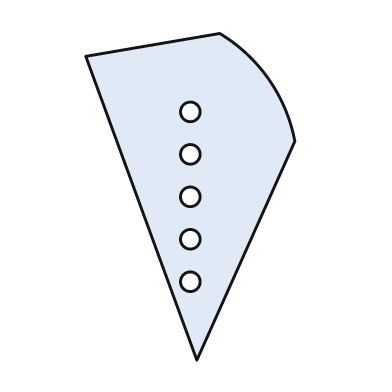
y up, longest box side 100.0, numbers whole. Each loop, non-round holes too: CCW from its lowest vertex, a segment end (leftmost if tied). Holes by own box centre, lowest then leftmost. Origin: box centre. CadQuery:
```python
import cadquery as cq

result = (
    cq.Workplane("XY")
    .moveTo(2.0, -50.0)
    .lineTo(32.0, 17.0)
    .threePointArc((24.0, 36.0), (9.0, 50.0))
    .lineTo(-32.0, 43.0)
    .close()
    .moveTo(0.0, -26.0)
    .circle(3.0)
    .moveTo(0.0, -13.0)
    .circle(3.0)
    .moveTo(0.0, 0.0)
    .circle(3.0)
    .moveTo(0.0, 13.0)
    .circle(3.0)
    .moveTo(0.0, 26.0)
    .circle(3.0)
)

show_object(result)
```